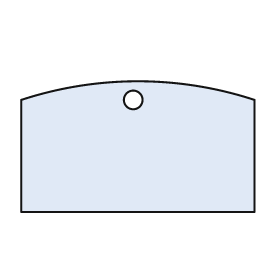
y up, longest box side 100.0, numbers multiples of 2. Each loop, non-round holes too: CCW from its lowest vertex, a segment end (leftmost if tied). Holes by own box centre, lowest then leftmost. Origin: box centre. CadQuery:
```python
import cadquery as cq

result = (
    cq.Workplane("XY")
    .moveTo(-50.0, -28.0)
    .lineTo(50.0, -28.0)
    .lineTo(50.0, 20.0)
    .threePointArc((0.0, 28.0), (-50.0, 20.0))
    .close()
    .moveTo(-2.0, 20.0)
    .circle(4.0)
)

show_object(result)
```